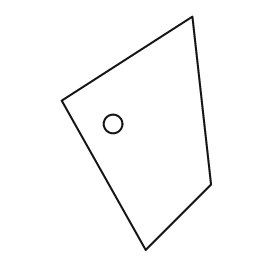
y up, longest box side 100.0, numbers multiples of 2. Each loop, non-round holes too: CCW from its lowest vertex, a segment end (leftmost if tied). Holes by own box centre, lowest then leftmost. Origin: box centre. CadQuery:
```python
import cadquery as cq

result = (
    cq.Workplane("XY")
    .moveTo(4.0, -50.0)
    .lineTo(32.0, -22.0)
    .lineTo(24.0, 50.0)
    .lineTo(-32.0, 14.0)
    .close()
    .moveTo(-10.0, 4.0)
    .circle(4.0)
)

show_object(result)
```